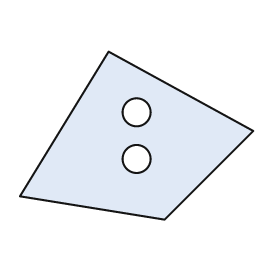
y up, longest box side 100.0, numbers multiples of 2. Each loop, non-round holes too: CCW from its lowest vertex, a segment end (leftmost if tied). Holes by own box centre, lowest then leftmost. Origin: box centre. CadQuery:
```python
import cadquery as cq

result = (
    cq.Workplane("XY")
    .moveTo(12.0, -36.0)
    .lineTo(50.0, 2.0)
    .lineTo(-12.0, 36.0)
    .lineTo(-50.0, -26.0)
    .close()
    .moveTo(0.0, -10.0)
    .circle(6.0)
    .moveTo(0.0, 10.0)
    .circle(6.0)
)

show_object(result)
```